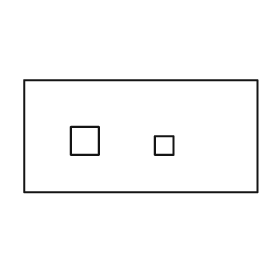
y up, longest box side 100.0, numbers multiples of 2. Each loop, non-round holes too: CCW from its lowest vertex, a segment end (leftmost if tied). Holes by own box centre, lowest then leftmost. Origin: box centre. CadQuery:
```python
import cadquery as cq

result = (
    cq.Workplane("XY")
    .moveTo(-50.0, -24.0)
    .lineTo(50.0, -24.0)
    .lineTo(50.0, 24.0)
    .lineTo(-50.0, 24.0)
    .close()
    .moveTo(6.0, -8.0)
    .lineTo(14.0, -8.0)
    .lineTo(14.0, 0.0)
    .lineTo(6.0, 0.0)
    .close()
    .moveTo(-30.0, -8.0)
    .lineTo(-18.0, -8.0)
    .lineTo(-18.0, 4.0)
    .lineTo(-30.0, 4.0)
    .close()
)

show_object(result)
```